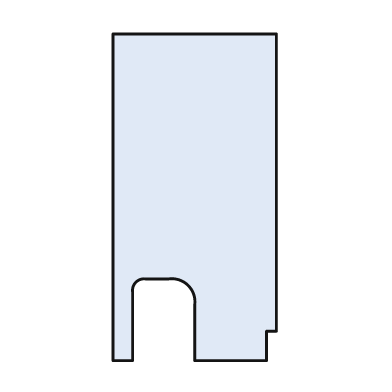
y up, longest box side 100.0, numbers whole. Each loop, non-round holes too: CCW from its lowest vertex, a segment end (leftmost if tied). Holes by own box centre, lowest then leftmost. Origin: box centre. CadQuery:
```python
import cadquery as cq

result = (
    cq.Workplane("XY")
    .moveTo(-25.0, -50.0)
    .lineTo(-19.0, -50.0)
    .lineTo(-19.0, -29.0)
    .threePointArc((-18.0, -26.0), (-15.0, -25.0))
    .lineTo(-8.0, -25.0)
    .threePointArc((-2.0, -27.0), (0.0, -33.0))
    .lineTo(0.0, -50.0)
    .lineTo(22.0, -50.0)
    .lineTo(22.0, -41.0)
    .lineTo(25.0, -41.0)
    .lineTo(25.0, 50.0)
    .lineTo(-25.0, 50.0)
    .close()
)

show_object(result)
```